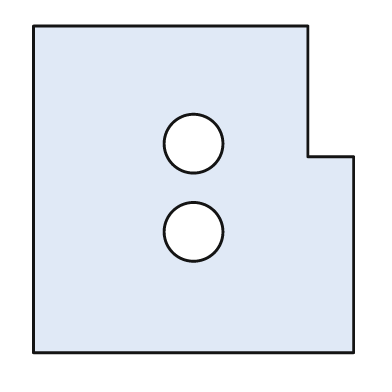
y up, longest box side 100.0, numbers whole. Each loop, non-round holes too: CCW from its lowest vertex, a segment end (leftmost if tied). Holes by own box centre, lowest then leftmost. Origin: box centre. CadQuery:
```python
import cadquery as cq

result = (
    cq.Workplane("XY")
    .moveTo(-49.0, -50.0)
    .lineTo(49.0, -50.0)
    .lineTo(49.0, 10.0)
    .lineTo(35.0, 10.0)
    .lineTo(35.0, 50.0)
    .lineTo(-49.0, 50.0)
    .close()
    .moveTo(0.0, -13.0)
    .circle(9.0)
    .moveTo(0.0, 14.0)
    .circle(9.0)
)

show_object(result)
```